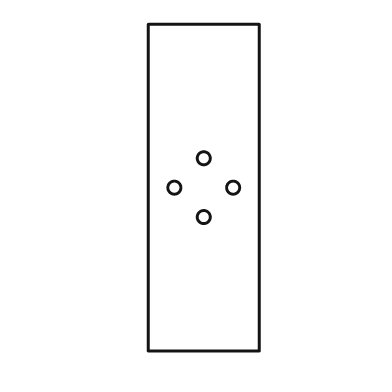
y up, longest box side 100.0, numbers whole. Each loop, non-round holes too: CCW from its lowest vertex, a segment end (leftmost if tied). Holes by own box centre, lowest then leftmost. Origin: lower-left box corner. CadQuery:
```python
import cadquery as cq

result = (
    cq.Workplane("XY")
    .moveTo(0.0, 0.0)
    .lineTo(34.0, 0.0)
    .lineTo(34.0, 100.0)
    .lineTo(0.0, 100.0)
    .close()
    .moveTo(17.0, 41.0)
    .circle(2.0)
    .moveTo(8.0, 50.0)
    .circle(2.0)
    .moveTo(26.0, 50.0)
    .circle(2.0)
    .moveTo(17.0, 59.0)
    .circle(2.0)
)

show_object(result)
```